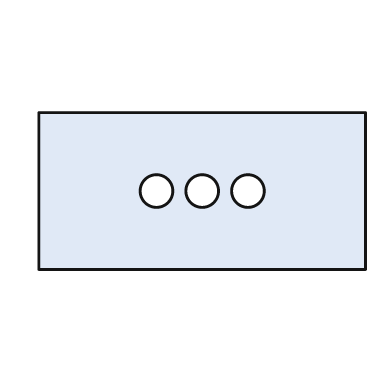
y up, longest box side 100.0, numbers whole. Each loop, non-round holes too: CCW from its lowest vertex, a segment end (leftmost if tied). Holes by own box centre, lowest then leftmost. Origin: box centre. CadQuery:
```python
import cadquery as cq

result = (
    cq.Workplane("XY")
    .moveTo(-50.0, -24.0)
    .lineTo(50.0, -24.0)
    .lineTo(50.0, 24.0)
    .lineTo(-50.0, 24.0)
    .close()
    .moveTo(-14.0, 0.0)
    .circle(5.0)
    .moveTo(0.0, 0.0)
    .circle(5.0)
    .moveTo(14.0, 0.0)
    .circle(5.0)
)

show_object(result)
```